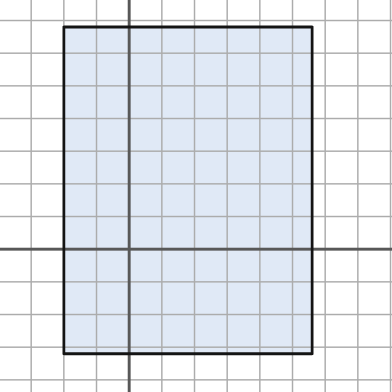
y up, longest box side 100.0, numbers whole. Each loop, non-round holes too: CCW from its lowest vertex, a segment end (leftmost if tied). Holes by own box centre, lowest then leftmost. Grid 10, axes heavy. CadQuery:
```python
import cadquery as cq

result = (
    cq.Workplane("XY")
    .moveTo(-20.0, -32.0)
    .lineTo(56.0, -32.0)
    .lineTo(56.0, 68.0)
    .lineTo(-20.0, 68.0)
    .close()
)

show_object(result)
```